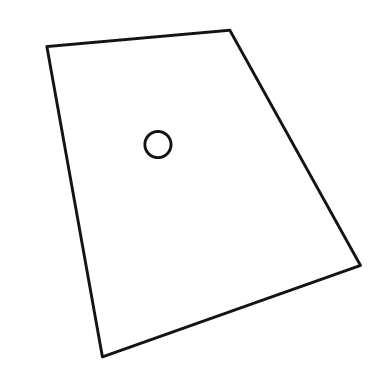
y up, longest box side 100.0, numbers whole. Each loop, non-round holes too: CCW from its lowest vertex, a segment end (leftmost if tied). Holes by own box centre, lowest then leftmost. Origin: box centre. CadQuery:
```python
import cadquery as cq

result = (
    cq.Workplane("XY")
    .moveTo(-31.0, -50.0)
    .lineTo(48.0, -22.0)
    .lineTo(8.0, 50.0)
    .lineTo(-48.0, 45.0)
    .close()
    .moveTo(-14.0, 15.0)
    .circle(4.0)
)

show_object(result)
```